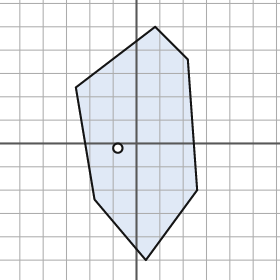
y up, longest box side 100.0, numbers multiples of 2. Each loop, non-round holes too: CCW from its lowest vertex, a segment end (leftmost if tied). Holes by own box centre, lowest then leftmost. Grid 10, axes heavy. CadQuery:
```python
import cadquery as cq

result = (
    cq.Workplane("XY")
    .moveTo(4.0, -50.0)
    .lineTo(26.0, -20.0)
    .lineTo(22.0, 36.0)
    .lineTo(8.0, 50.0)
    .lineTo(-26.0, 24.0)
    .lineTo(-18.0, -24.0)
    .close()
    .moveTo(-8.0, -2.0)
    .circle(2.0)
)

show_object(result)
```